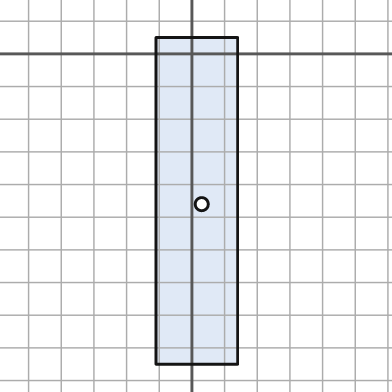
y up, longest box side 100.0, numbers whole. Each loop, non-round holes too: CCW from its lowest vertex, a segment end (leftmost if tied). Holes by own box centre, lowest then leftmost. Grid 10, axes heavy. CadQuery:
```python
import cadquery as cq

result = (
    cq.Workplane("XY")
    .moveTo(-11.0, -95.0)
    .lineTo(14.0, -95.0)
    .lineTo(14.0, 5.0)
    .lineTo(-11.0, 5.0)
    .close()
    .moveTo(3.0, -46.0)
    .circle(2.0)
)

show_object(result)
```